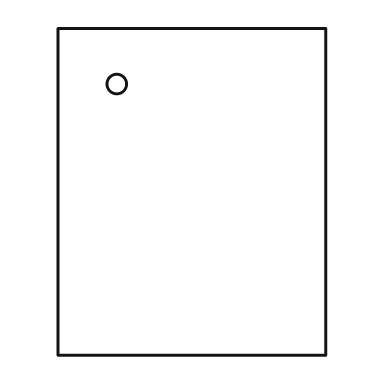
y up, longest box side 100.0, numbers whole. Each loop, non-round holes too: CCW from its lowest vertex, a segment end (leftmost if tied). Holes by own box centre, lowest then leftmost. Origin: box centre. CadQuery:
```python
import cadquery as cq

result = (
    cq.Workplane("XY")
    .moveTo(-41.0, -50.0)
    .lineTo(41.0, -50.0)
    .lineTo(41.0, 50.0)
    .lineTo(-41.0, 50.0)
    .close()
    .moveTo(-23.0, 33.0)
    .circle(3.0)
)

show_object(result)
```